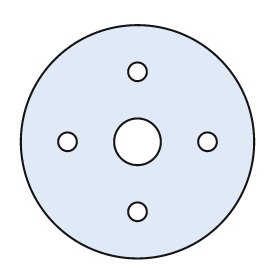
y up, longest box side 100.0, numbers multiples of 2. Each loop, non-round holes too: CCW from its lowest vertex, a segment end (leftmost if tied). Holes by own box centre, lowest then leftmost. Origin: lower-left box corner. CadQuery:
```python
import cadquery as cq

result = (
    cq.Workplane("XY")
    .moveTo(50.0, 50.0)
    .circle(50.0)
    .moveTo(50.0, 20.0)
    .circle(4.0)
    .moveTo(20.0, 50.0)
    .circle(4.0)
    .moveTo(50.0, 50.0)
    .circle(10.0)
    .moveTo(80.0, 50.0)
    .circle(4.0)
    .moveTo(50.0, 80.0)
    .circle(4.0)
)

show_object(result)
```